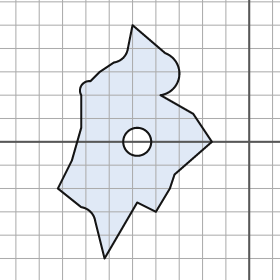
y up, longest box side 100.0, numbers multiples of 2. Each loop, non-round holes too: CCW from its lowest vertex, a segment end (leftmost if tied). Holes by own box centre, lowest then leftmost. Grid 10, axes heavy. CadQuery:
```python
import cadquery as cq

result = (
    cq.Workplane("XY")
    .moveTo(-62.0, -50.0)
    .lineTo(-48.0, -26.0)
    .lineTo(-40.0, -30.0)
    .lineTo(-34.0, -20.0)
    .lineTo(-32.0, -14.0)
    .lineTo(-16.0, 0.0)
    .lineTo(-24.0, 12.0)
    .lineTo(-38.0, 20.0)
    .threePointArc((-30.0, 28.0), (-36.0, 38.0))
    .lineTo(-50.0, 50.0)
    .lineTo(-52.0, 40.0)
    .threePointArc((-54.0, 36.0), (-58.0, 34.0))
    .lineTo(-64.0, 30.0)
    .lineTo(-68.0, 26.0)
    .threePointArc((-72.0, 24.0), (-72.0, 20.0))
    .lineTo(-72.0, 6.0)
    .lineTo(-76.0, -8.0)
    .lineTo(-82.0, -20.0)
    .lineTo(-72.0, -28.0)
    .threePointArc((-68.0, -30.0), (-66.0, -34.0))
    .close()
    .moveTo(-48.0, 0.0)
    .circle(6.0)
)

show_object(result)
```